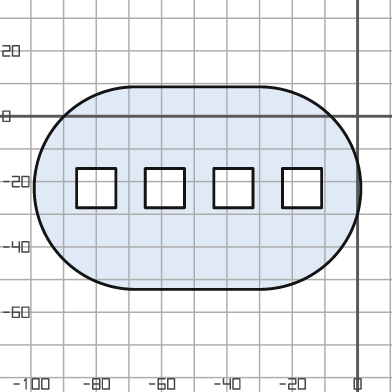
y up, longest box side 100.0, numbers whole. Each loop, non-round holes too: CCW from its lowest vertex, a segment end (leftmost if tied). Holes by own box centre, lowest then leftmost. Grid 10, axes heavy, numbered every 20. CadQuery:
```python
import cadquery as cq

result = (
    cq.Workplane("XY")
    .moveTo(-68.0, -53.0)
    .lineTo(-30.0, -53.0)
    .threePointArc((1.0, -22.0), (-30.0, 9.0))
    .lineTo(-68.0, 9.0)
    .threePointArc((-99.0, -22.0), (-68.0, -53.0))
    .close()
    .moveTo(-86.0, -28.0)
    .lineTo(-74.0, -28.0)
    .lineTo(-74.0, -16.0)
    .lineTo(-86.0, -16.0)
    .close()
    .moveTo(-65.0, -28.0)
    .lineTo(-53.0, -28.0)
    .lineTo(-53.0, -16.0)
    .lineTo(-65.0, -16.0)
    .close()
    .moveTo(-44.0, -28.0)
    .lineTo(-32.0, -28.0)
    .lineTo(-32.0, -16.0)
    .lineTo(-44.0, -16.0)
    .close()
    .moveTo(-23.0, -28.0)
    .lineTo(-11.0, -28.0)
    .lineTo(-11.0, -16.0)
    .lineTo(-23.0, -16.0)
    .close()
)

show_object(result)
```